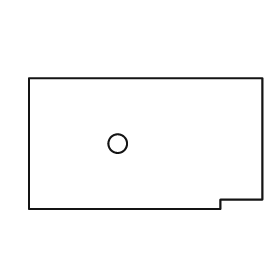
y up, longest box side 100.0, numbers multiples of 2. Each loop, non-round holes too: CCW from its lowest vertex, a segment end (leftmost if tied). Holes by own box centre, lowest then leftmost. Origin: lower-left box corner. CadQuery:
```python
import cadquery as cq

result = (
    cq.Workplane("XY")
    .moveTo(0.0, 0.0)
    .lineTo(82.0, 0.0)
    .lineTo(82.0, 4.0)
    .lineTo(100.0, 4.0)
    .lineTo(100.0, 56.0)
    .lineTo(0.0, 56.0)
    .close()
    .moveTo(38.0, 28.0)
    .circle(4.0)
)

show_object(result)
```